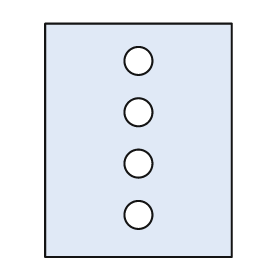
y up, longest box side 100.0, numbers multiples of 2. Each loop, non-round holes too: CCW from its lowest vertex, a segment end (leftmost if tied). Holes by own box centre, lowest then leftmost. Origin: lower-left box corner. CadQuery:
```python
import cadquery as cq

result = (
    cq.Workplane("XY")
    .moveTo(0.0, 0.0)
    .lineTo(80.0, 0.0)
    .lineTo(80.0, 100.0)
    .lineTo(0.0, 100.0)
    .close()
    .moveTo(40.0, 18.0)
    .circle(6.0)
    .moveTo(40.0, 40.0)
    .circle(6.0)
    .moveTo(40.0, 62.0)
    .circle(6.0)
    .moveTo(40.0, 84.0)
    .circle(6.0)
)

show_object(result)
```